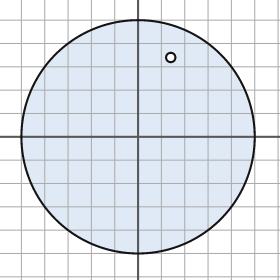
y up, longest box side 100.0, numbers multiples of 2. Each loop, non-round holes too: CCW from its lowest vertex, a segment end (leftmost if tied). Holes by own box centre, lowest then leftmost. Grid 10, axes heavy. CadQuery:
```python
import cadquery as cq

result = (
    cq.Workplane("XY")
    .moveTo(0.0, 0.0)
    .circle(50.0)
    .moveTo(14.0, 34.0)
    .circle(2.0)
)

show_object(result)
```